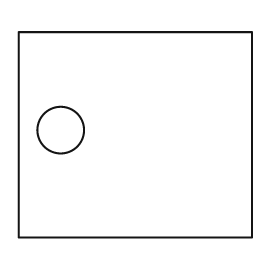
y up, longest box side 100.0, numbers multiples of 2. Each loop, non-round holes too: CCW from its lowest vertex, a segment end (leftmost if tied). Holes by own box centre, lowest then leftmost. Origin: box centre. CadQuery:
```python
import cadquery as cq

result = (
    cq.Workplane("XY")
    .moveTo(-50.0, -44.0)
    .lineTo(50.0, -44.0)
    .lineTo(50.0, 44.0)
    .lineTo(-50.0, 44.0)
    .close()
    .moveTo(-32.0, 2.0)
    .circle(10.0)
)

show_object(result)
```